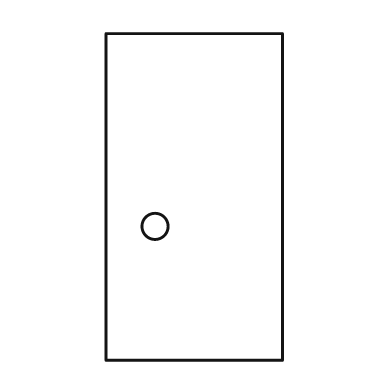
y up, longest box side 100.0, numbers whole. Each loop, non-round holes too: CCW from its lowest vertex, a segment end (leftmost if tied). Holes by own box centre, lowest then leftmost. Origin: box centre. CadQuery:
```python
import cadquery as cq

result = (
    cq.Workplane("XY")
    .moveTo(-27.0, -50.0)
    .lineTo(27.0, -50.0)
    .lineTo(27.0, 50.0)
    .lineTo(-27.0, 50.0)
    .close()
    .moveTo(-12.0, -9.0)
    .circle(4.0)
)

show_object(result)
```